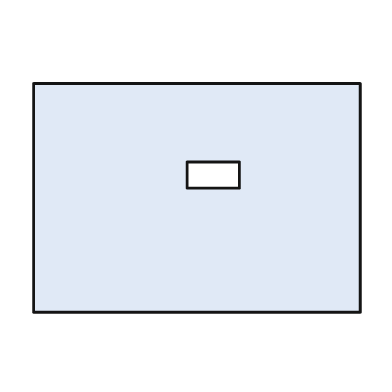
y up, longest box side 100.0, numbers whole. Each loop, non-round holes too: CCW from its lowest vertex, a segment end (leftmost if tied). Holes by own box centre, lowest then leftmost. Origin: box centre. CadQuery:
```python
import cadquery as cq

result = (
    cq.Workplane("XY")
    .moveTo(-50.0, -35.0)
    .lineTo(50.0, -35.0)
    .lineTo(50.0, 35.0)
    .lineTo(-50.0, 35.0)
    .close()
    .moveTo(-3.0, 3.0)
    .lineTo(13.0, 3.0)
    .lineTo(13.0, 11.0)
    .lineTo(-3.0, 11.0)
    .close()
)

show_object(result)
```